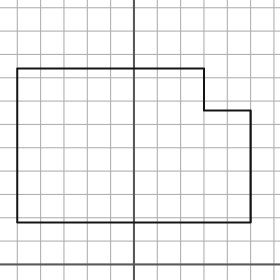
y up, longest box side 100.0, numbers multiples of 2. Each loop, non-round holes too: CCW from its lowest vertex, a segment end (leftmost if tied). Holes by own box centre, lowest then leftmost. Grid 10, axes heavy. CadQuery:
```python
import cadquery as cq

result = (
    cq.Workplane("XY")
    .moveTo(-50.0, 18.0)
    .lineTo(50.0, 18.0)
    .lineTo(50.0, 66.0)
    .lineTo(30.0, 66.0)
    .lineTo(30.0, 84.0)
    .lineTo(-50.0, 84.0)
    .close()
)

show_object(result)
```